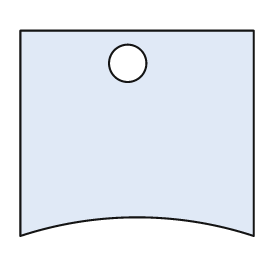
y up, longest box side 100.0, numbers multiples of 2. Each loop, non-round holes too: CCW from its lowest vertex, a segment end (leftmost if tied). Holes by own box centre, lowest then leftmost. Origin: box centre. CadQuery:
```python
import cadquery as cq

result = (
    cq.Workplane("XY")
    .moveTo(-50.0, -44.0)
    .threePointArc((0.0, -36.0), (50.0, -44.0))
    .lineTo(50.0, 44.0)
    .lineTo(-50.0, 44.0)
    .close()
    .moveTo(-4.0, 30.0)
    .circle(8.0)
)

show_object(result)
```